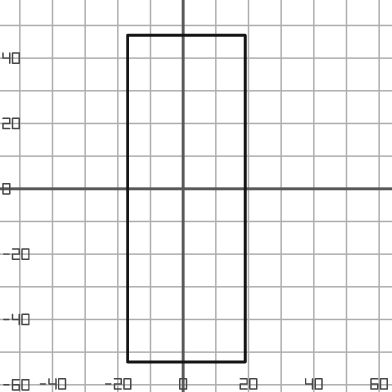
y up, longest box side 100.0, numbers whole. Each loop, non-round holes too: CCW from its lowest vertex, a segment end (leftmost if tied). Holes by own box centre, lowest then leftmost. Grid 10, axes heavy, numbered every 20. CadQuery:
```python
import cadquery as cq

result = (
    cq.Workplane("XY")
    .moveTo(-17.0, -53.0)
    .lineTo(19.0, -53.0)
    .lineTo(19.0, 47.0)
    .lineTo(-17.0, 47.0)
    .close()
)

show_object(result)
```